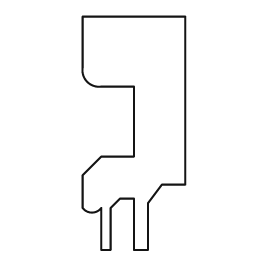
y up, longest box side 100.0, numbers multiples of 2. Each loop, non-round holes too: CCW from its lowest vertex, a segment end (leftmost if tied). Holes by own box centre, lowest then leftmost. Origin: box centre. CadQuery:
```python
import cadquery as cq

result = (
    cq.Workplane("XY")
    .moveTo(-14.0, -50.0)
    .lineTo(-10.0, -50.0)
    .lineTo(-10.0, -32.0)
    .lineTo(-6.0, -28.0)
    .lineTo(0.0, -28.0)
    .lineTo(0.0, -50.0)
    .lineTo(6.0, -50.0)
    .lineTo(6.0, -30.0)
    .lineTo(12.0, -22.0)
    .lineTo(22.0, -22.0)
    .lineTo(22.0, 50.0)
    .lineTo(-22.0, 50.0)
    .lineTo(-22.0, 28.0)
    .threePointArc((-20.0, 22.0), (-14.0, 20.0))
    .lineTo(0.0, 20.0)
    .lineTo(0.0, -10.0)
    .lineTo(-14.0, -10.0)
    .lineTo(-22.0, -18.0)
    .lineTo(-22.0, -32.0)
    .threePointArc((-18.0, -34.0), (-14.0, -32.0))
    .close()
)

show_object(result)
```